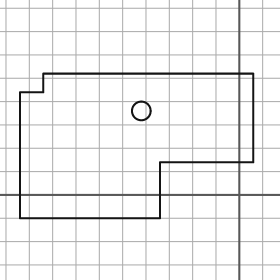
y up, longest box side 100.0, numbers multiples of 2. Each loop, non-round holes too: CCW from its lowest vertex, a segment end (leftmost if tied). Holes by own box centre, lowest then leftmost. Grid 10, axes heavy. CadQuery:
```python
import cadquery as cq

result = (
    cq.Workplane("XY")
    .moveTo(-94.0, -10.0)
    .lineTo(-34.0, -10.0)
    .lineTo(-34.0, 14.0)
    .lineTo(6.0, 14.0)
    .lineTo(6.0, 52.0)
    .lineTo(-84.0, 52.0)
    .lineTo(-84.0, 44.0)
    .lineTo(-94.0, 44.0)
    .close()
    .moveTo(-42.0, 36.0)
    .circle(4.0)
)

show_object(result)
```